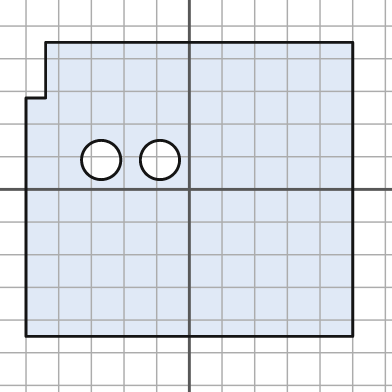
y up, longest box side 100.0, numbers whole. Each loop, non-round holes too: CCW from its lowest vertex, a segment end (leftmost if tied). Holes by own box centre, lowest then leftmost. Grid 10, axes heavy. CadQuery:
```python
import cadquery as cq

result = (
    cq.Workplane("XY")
    .moveTo(-50.0, -45.0)
    .lineTo(50.0, -45.0)
    .lineTo(50.0, 45.0)
    .lineTo(-44.0, 45.0)
    .lineTo(-44.0, 28.0)
    .lineTo(-50.0, 28.0)
    .close()
    .moveTo(-27.0, 9.0)
    .circle(6.0)
    .moveTo(-9.0, 9.0)
    .circle(6.0)
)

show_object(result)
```